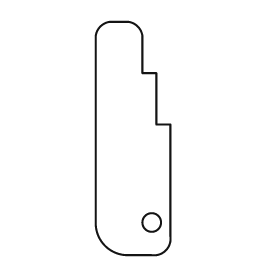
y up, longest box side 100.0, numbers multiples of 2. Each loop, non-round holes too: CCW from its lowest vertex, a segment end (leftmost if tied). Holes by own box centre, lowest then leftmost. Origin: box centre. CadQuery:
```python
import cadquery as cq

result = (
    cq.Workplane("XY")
    .moveTo(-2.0, -50.0)
    .lineTo(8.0, -50.0)
    .threePointArc((14.0, -48.0), (16.0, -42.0))
    .lineTo(16.0, 6.0)
    .lineTo(10.0, 6.0)
    .lineTo(10.0, 28.0)
    .lineTo(4.0, 28.0)
    .lineTo(4.0, 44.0)
    .threePointArc((2.0, 48.0), (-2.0, 50.0))
    .lineTo(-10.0, 50.0)
    .threePointArc((-14.0, 48.0), (-16.0, 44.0))
    .lineTo(-16.0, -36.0)
    .threePointArc((-12.0, -46.0), (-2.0, -50.0))
    .close()
    .moveTo(8.0, -36.0)
    .circle(4.0)
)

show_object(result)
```